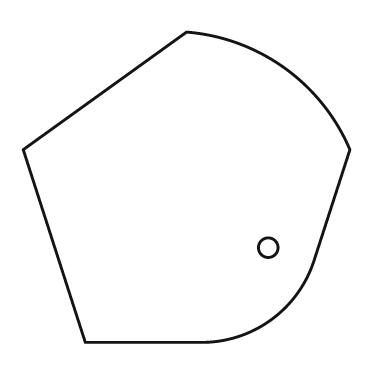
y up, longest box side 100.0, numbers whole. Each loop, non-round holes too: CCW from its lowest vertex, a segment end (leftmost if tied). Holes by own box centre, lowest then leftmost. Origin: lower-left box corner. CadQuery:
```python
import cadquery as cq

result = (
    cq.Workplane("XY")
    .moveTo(19.0, 0.0)
    .lineTo(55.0, 0.0)
    .threePointArc((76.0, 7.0), (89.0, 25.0))
    .lineTo(100.0, 59.0)
    .threePointArc((80.0, 84.0), (50.0, 95.0))
    .lineTo(0.0, 59.0)
    .close()
    .moveTo(75.0, 29.0)
    .circle(3.0)
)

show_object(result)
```